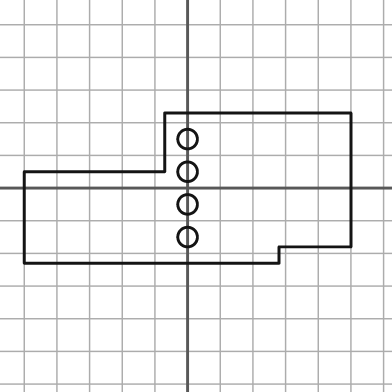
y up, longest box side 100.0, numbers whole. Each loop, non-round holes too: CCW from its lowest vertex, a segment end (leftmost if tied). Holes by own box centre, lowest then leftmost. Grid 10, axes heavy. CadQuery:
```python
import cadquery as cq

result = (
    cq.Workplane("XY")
    .moveTo(-50.0, -23.0)
    .lineTo(28.0, -23.0)
    .lineTo(28.0, -18.0)
    .lineTo(50.0, -18.0)
    .lineTo(50.0, 23.0)
    .lineTo(-7.0, 23.0)
    .lineTo(-7.0, 5.0)
    .lineTo(-50.0, 5.0)
    .close()
    .moveTo(0.0, -15.0)
    .circle(3.0)
    .moveTo(0.0, -5.0)
    .circle(3.0)
    .moveTo(0.0, 5.0)
    .circle(3.0)
    .moveTo(0.0, 15.0)
    .circle(3.0)
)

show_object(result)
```